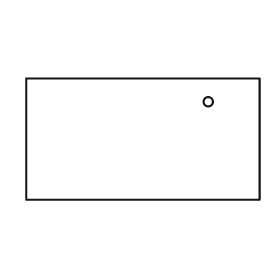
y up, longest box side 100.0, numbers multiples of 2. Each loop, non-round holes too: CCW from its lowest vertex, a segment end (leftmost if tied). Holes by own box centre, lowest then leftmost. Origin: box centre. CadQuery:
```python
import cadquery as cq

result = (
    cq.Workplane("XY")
    .moveTo(-50.0, -26.0)
    .lineTo(50.0, -26.0)
    .lineTo(50.0, 26.0)
    .lineTo(-50.0, 26.0)
    .close()
    .moveTo(28.0, 16.0)
    .circle(2.0)
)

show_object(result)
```